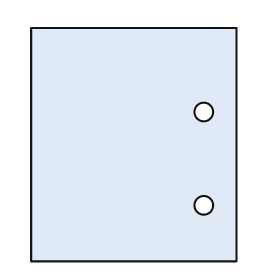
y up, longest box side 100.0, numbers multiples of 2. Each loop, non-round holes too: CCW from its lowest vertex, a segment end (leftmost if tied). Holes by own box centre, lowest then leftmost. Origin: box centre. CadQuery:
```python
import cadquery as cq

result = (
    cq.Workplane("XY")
    .moveTo(-44.0, -50.0)
    .lineTo(44.0, -50.0)
    .lineTo(44.0, 50.0)
    .lineTo(-44.0, 50.0)
    .close()
    .moveTo(30.0, -26.0)
    .circle(4.0)
    .moveTo(30.0, 14.0)
    .circle(4.0)
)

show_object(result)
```